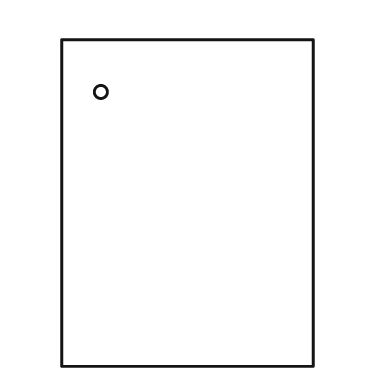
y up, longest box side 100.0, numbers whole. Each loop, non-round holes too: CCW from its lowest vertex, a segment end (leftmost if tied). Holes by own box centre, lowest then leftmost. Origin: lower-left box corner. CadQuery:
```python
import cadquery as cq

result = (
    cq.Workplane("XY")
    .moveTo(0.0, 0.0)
    .lineTo(77.0, 0.0)
    .lineTo(77.0, 100.0)
    .lineTo(0.0, 100.0)
    .close()
    .moveTo(12.0, 84.0)
    .circle(2.0)
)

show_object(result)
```